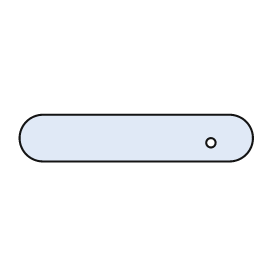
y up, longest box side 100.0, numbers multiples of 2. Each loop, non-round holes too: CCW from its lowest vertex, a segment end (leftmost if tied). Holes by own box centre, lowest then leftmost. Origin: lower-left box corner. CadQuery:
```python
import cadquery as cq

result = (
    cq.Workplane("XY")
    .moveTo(10.0, 0.0)
    .lineTo(90.0, 0.0)
    .threePointArc((100.0, 10.0), (90.0, 20.0))
    .lineTo(10.0, 20.0)
    .threePointArc((0.0, 10.0), (10.0, 0.0))
    .close()
    .moveTo(82.0, 8.0)
    .circle(2.0)
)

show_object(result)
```